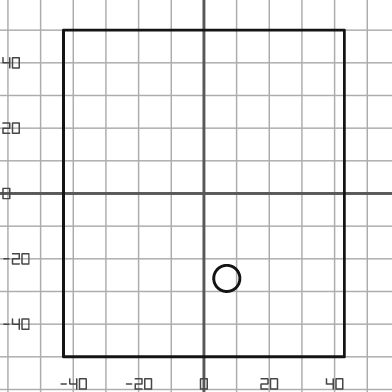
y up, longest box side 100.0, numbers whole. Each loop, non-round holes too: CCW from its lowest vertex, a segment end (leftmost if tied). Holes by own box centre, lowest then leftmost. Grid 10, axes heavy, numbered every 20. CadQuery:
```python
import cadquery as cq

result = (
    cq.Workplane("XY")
    .moveTo(-43.0, -50.0)
    .lineTo(43.0, -50.0)
    .lineTo(43.0, 50.0)
    .lineTo(-43.0, 50.0)
    .close()
    .moveTo(7.0, -26.0)
    .circle(4.0)
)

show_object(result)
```